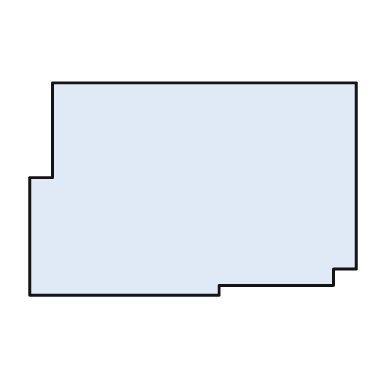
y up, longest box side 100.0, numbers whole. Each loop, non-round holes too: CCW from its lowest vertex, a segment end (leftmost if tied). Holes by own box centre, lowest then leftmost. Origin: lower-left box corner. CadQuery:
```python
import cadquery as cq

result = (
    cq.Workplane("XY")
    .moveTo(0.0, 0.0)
    .lineTo(58.0, 0.0)
    .lineTo(58.0, 3.0)
    .lineTo(93.0, 3.0)
    .lineTo(93.0, 8.0)
    .lineTo(100.0, 8.0)
    .lineTo(100.0, 65.0)
    .lineTo(7.0, 65.0)
    .lineTo(7.0, 36.0)
    .lineTo(0.0, 36.0)
    .close()
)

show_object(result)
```